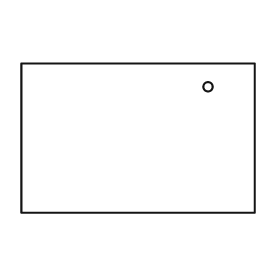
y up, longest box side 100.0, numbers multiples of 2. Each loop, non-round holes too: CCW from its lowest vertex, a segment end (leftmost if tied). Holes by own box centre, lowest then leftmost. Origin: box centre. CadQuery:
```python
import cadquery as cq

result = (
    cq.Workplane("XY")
    .moveTo(-50.0, -32.0)
    .lineTo(50.0, -32.0)
    .lineTo(50.0, 32.0)
    .lineTo(-50.0, 32.0)
    .close()
    .moveTo(30.0, 22.0)
    .circle(2.0)
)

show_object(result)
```